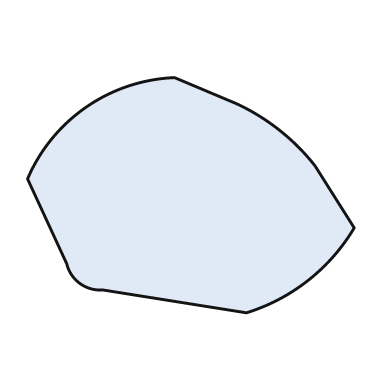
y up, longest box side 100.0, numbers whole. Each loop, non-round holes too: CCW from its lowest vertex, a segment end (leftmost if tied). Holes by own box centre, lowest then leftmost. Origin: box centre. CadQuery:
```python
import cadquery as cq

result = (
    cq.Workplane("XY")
    .moveTo(17.0, -36.0)
    .threePointArc((36.0, -26.0), (50.0, -10.0))
    .lineTo(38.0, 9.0)
    .threePointArc((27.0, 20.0), (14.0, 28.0))
    .lineTo(-5.0, 36.0)
    .threePointArc((-32.0, 27.0), (-50.0, 5.0))
    .lineTo(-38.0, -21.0)
    .threePointArc((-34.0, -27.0), (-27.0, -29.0))
    .close()
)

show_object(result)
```